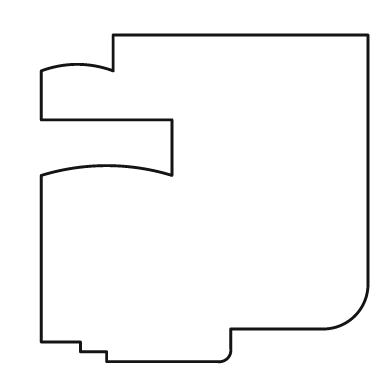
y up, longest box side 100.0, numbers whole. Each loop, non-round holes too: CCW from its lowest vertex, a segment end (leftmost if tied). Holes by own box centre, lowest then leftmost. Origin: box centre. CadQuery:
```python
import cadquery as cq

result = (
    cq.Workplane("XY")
    .moveTo(-30.0, -50.0)
    .lineTo(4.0, -50.0)
    .threePointArc((7.0, -49.0), (8.0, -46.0))
    .lineTo(8.0, -40.0)
    .lineTo(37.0, -40.0)
    .threePointArc((46.0, -36.0), (50.0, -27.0))
    .lineTo(50.0, 50.0)
    .lineTo(-28.0, 50.0)
    .lineTo(-28.0, 39.0)
    .threePointArc((-39.0, 41.0), (-50.0, 39.0))
    .lineTo(-50.0, 24.0)
    .lineTo(-10.0, 24.0)
    .lineTo(-10.0, 7.0)
    .threePointArc((-30.0, 10.0), (-50.0, 7.0))
    .lineTo(-50.0, -44.0)
    .lineTo(-38.0, -44.0)
    .lineTo(-38.0, -47.0)
    .lineTo(-30.0, -47.0)
    .close()
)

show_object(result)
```